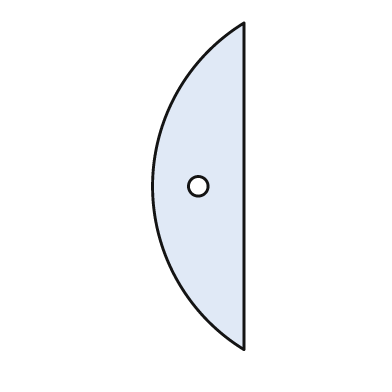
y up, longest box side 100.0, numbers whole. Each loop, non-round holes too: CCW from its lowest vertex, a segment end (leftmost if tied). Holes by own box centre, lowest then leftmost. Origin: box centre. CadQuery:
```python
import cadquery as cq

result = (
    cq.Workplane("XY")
    .moveTo(14.0, -50.0)
    .lineTo(14.0, 50.0)
    .threePointArc((-14.0, 0.0), (14.0, -50.0))
    .close()
    .moveTo(0.0, 0.0)
    .circle(3.0)
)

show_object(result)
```